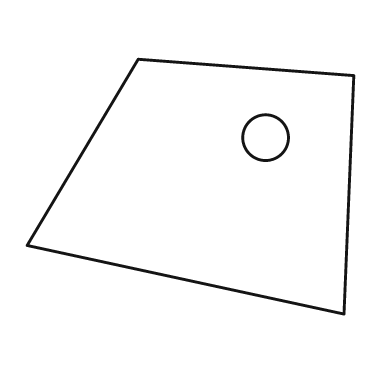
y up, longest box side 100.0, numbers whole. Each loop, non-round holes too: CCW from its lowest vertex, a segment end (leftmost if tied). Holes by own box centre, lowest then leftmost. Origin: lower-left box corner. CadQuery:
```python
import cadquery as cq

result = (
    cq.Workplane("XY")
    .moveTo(97.0, 0.0)
    .lineTo(100.0, 73.0)
    .lineTo(34.0, 78.0)
    .lineTo(0.0, 21.0)
    .close()
    .moveTo(73.0, 54.0)
    .circle(7.0)
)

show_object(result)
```